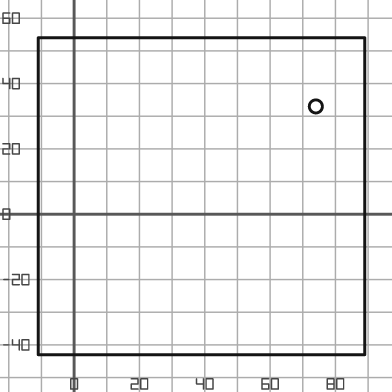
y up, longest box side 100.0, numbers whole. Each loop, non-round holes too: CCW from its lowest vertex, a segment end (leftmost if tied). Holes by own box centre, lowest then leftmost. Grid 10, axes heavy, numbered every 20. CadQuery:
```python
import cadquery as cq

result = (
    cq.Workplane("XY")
    .moveTo(-11.0, -43.0)
    .lineTo(89.0, -43.0)
    .lineTo(89.0, 54.0)
    .lineTo(-11.0, 54.0)
    .close()
    .moveTo(74.0, 33.0)
    .circle(2.0)
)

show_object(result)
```